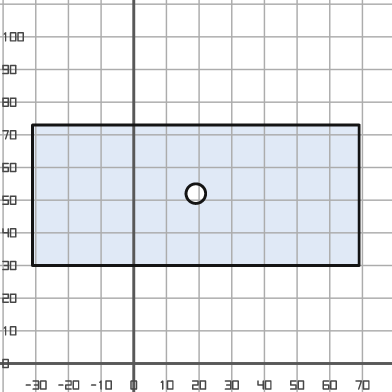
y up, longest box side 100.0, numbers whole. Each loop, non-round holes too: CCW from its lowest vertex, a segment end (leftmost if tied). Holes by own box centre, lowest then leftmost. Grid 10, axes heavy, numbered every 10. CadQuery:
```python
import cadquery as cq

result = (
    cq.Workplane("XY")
    .moveTo(-31.0, 30.0)
    .lineTo(69.0, 30.0)
    .lineTo(69.0, 73.0)
    .lineTo(-31.0, 73.0)
    .close()
    .moveTo(19.0, 52.0)
    .circle(3.0)
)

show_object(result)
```